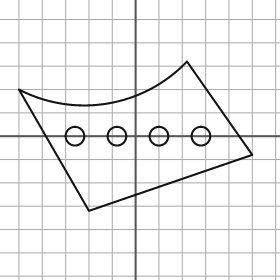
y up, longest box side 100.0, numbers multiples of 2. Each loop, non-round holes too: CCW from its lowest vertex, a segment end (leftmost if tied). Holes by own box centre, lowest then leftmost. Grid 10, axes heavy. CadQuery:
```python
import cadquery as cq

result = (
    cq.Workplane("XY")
    .moveTo(-20.0, -32.0)
    .lineTo(50.0, -8.0)
    .lineTo(22.0, 32.0)
    .threePointArc((-12.0, 14.0), (-50.0, 20.0))
    .close()
    .moveTo(-26.0, 0.0)
    .circle(4.0)
    .moveTo(-8.0, 0.0)
    .circle(4.0)
    .moveTo(10.0, 0.0)
    .circle(4.0)
    .moveTo(28.0, 0.0)
    .circle(4.0)
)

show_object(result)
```